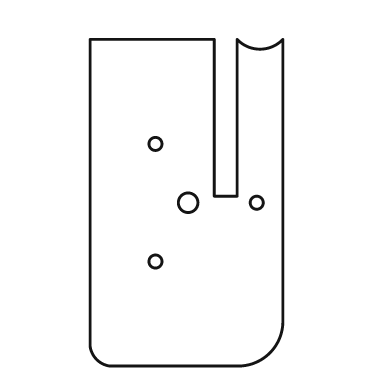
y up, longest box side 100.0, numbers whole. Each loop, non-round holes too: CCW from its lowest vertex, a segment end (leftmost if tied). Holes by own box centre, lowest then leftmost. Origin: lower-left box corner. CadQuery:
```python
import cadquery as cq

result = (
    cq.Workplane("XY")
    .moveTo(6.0, 0.0)
    .lineTo(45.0, 0.0)
    .threePointArc((55.0, 4.0), (59.0, 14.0))
    .lineTo(59.0, 100.0)
    .threePointArc((52.0, 97.0), (45.0, 100.0))
    .lineTo(45.0, 52.0)
    .lineTo(38.0, 52.0)
    .lineTo(38.0, 100.0)
    .lineTo(0.0, 100.0)
    .lineTo(0.0, 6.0)
    .threePointArc((2.0, 2.0), (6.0, 0.0))
    .close()
    .moveTo(20.0, 32.0)
    .circle(2.0)
    .moveTo(30.0, 50.0)
    .circle(3.0)
    .moveTo(51.0, 50.0)
    .circle(2.0)
    .moveTo(20.0, 68.0)
    .circle(2.0)
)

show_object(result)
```